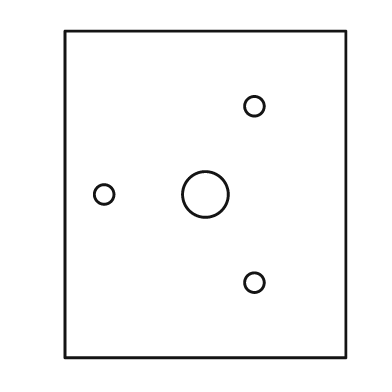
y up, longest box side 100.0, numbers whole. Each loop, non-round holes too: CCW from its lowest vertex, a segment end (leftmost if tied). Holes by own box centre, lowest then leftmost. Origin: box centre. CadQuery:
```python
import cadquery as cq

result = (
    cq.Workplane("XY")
    .moveTo(-43.0, -50.0)
    .lineTo(43.0, -50.0)
    .lineTo(43.0, 50.0)
    .lineTo(-43.0, 50.0)
    .close()
    .moveTo(15.0, -27.0)
    .circle(3.0)
    .moveTo(-31.0, 0.0)
    .circle(3.0)
    .moveTo(0.0, 0.0)
    .circle(7.0)
    .moveTo(15.0, 27.0)
    .circle(3.0)
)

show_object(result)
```